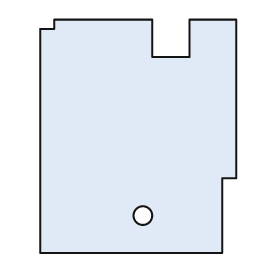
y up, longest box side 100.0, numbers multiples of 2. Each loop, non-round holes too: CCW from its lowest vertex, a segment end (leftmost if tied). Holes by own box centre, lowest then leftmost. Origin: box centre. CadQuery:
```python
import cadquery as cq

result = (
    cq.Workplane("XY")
    .moveTo(-42.0, -50.0)
    .lineTo(36.0, -50.0)
    .lineTo(36.0, -18.0)
    .lineTo(42.0, -18.0)
    .lineTo(42.0, 50.0)
    .lineTo(22.0, 50.0)
    .lineTo(22.0, 34.0)
    .lineTo(6.0, 34.0)
    .lineTo(6.0, 50.0)
    .lineTo(-36.0, 50.0)
    .lineTo(-36.0, 46.0)
    .lineTo(-42.0, 46.0)
    .close()
    .moveTo(2.0, -34.0)
    .circle(4.0)
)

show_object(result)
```